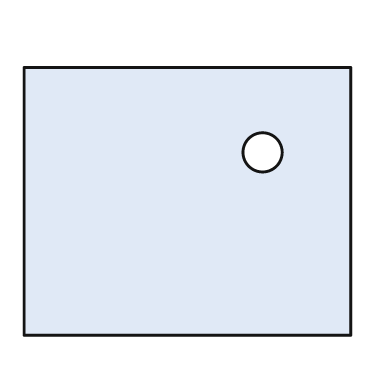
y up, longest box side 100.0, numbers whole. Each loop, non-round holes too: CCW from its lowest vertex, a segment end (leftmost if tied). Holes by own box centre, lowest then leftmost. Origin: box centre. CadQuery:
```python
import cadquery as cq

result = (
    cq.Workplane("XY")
    .moveTo(-50.0, -41.0)
    .lineTo(50.0, -41.0)
    .lineTo(50.0, 41.0)
    .lineTo(-50.0, 41.0)
    .close()
    .moveTo(23.0, 15.0)
    .circle(6.0)
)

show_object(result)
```